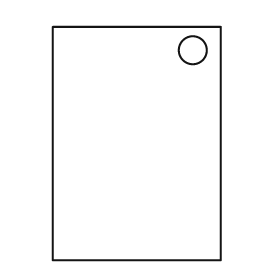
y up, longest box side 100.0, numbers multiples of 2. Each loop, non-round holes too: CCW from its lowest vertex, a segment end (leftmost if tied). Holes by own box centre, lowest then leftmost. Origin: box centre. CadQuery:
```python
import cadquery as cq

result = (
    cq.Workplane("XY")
    .moveTo(-36.0, -50.0)
    .lineTo(36.0, -50.0)
    .lineTo(36.0, 50.0)
    .lineTo(-36.0, 50.0)
    .close()
    .moveTo(24.0, 40.0)
    .circle(6.0)
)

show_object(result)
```